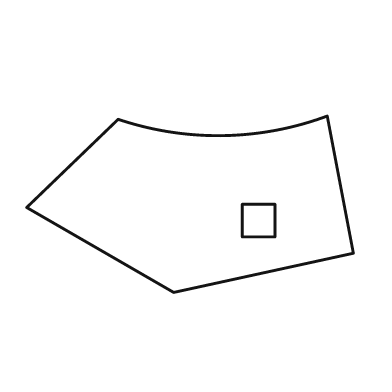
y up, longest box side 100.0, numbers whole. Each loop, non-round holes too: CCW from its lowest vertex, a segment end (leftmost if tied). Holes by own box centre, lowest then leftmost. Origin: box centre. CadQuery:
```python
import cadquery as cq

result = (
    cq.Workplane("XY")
    .moveTo(-5.0, -27.0)
    .lineTo(50.0, -15.0)
    .lineTo(42.0, 27.0)
    .threePointArc((10.0, 21.0), (-22.0, 26.0))
    .lineTo(-50.0, -1.0)
    .close()
    .moveTo(16.0, -10.0)
    .lineTo(26.0, -10.0)
    .lineTo(26.0, 0.0)
    .lineTo(16.0, 0.0)
    .close()
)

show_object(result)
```